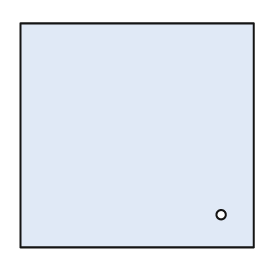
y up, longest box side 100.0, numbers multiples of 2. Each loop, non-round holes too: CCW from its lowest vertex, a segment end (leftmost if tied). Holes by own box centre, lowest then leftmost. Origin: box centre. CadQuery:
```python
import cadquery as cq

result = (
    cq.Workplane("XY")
    .moveTo(-50.0, -48.0)
    .lineTo(50.0, -48.0)
    .lineTo(50.0, 48.0)
    .lineTo(-50.0, 48.0)
    .close()
    .moveTo(36.0, -34.0)
    .circle(2.0)
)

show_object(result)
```